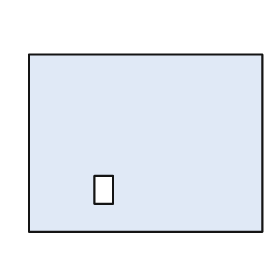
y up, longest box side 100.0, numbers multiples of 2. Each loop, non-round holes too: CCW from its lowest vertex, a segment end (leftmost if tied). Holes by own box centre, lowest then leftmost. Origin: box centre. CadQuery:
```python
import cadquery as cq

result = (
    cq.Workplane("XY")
    .moveTo(-50.0, -38.0)
    .lineTo(50.0, -38.0)
    .lineTo(50.0, 38.0)
    .lineTo(-50.0, 38.0)
    .close()
    .moveTo(-22.0, -26.0)
    .lineTo(-14.0, -26.0)
    .lineTo(-14.0, -14.0)
    .lineTo(-22.0, -14.0)
    .close()
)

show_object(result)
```